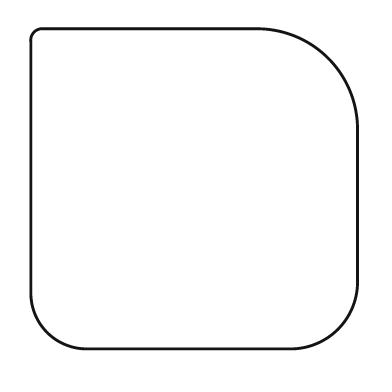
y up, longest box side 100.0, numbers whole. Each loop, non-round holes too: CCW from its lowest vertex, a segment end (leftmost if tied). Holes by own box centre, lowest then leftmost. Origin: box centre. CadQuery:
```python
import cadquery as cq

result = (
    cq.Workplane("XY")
    .moveTo(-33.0, -49.0)
    .lineTo(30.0, -49.0)
    .threePointArc((44.0, -43.0), (50.0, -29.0))
    .lineTo(50.0, 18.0)
    .threePointArc((41.0, 40.0), (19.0, 49.0))
    .lineTo(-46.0, 49.0)
    .threePointArc((-49.0, 48.0), (-50.0, 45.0))
    .lineTo(-50.0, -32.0)
    .threePointArc((-45.0, -44.0), (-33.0, -49.0))
    .close()
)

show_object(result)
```